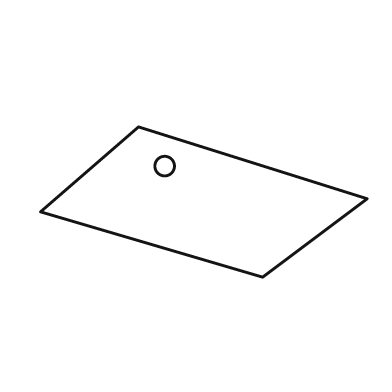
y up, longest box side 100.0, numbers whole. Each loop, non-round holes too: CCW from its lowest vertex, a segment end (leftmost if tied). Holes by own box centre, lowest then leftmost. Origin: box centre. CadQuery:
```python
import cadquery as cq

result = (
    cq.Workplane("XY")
    .moveTo(18.0, -23.0)
    .lineTo(50.0, 1.0)
    .lineTo(-20.0, 23.0)
    .lineTo(-50.0, -3.0)
    .close()
    .moveTo(-12.0, 11.0)
    .circle(3.0)
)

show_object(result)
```